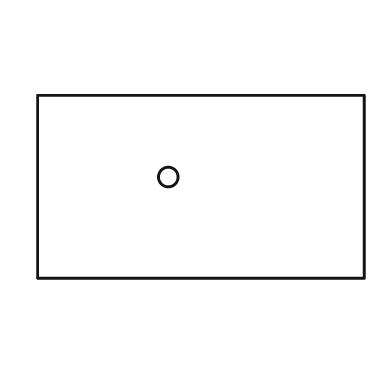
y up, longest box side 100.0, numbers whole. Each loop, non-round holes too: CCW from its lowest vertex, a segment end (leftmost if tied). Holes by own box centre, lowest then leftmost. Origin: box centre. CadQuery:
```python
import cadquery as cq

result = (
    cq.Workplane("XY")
    .moveTo(-50.0, -28.0)
    .lineTo(50.0, -28.0)
    .lineTo(50.0, 28.0)
    .lineTo(-50.0, 28.0)
    .close()
    .moveTo(-10.0, 3.0)
    .circle(3.0)
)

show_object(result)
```